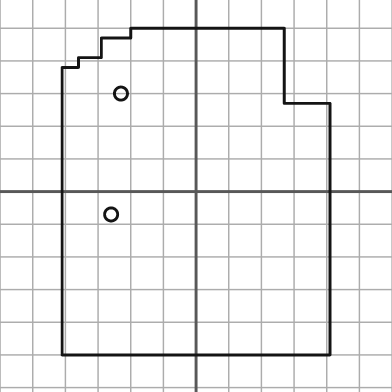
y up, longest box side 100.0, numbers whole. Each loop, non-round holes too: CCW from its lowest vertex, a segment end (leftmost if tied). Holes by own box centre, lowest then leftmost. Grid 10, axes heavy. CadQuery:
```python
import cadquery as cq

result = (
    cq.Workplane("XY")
    .moveTo(-41.0, -50.0)
    .lineTo(41.0, -50.0)
    .lineTo(41.0, 27.0)
    .lineTo(27.0, 27.0)
    .lineTo(27.0, 50.0)
    .lineTo(-20.0, 50.0)
    .lineTo(-20.0, 47.0)
    .lineTo(-29.0, 47.0)
    .lineTo(-29.0, 41.0)
    .lineTo(-36.0, 41.0)
    .lineTo(-36.0, 38.0)
    .lineTo(-41.0, 38.0)
    .close()
    .moveTo(-26.0, -7.0)
    .circle(2.0)
    .moveTo(-23.0, 30.0)
    .circle(2.0)
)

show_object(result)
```